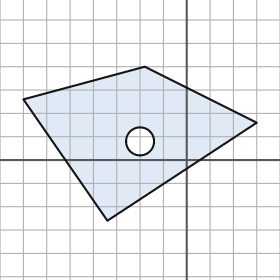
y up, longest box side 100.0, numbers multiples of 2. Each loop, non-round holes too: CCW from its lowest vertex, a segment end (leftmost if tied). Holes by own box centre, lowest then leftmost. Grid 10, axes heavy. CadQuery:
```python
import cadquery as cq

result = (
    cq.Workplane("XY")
    .moveTo(-34.0, -26.0)
    .lineTo(30.0, 16.0)
    .lineTo(-18.0, 40.0)
    .lineTo(-70.0, 26.0)
    .close()
    .moveTo(-20.0, 8.0)
    .circle(6.0)
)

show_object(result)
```